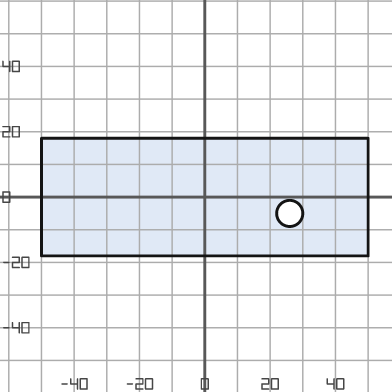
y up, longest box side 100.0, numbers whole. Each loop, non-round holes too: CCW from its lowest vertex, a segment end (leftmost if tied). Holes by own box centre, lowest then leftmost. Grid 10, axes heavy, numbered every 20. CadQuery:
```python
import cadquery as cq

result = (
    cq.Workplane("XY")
    .moveTo(-50.0, -18.0)
    .lineTo(50.0, -18.0)
    .lineTo(50.0, 18.0)
    .lineTo(-50.0, 18.0)
    .close()
    .moveTo(26.0, -5.0)
    .circle(4.0)
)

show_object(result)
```